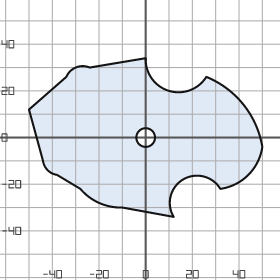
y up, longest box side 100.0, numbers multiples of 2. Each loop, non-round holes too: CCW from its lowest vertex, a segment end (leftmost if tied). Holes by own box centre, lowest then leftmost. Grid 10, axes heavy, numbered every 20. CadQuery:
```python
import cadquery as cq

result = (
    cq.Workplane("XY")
    .moveTo(12.0, -34.0)
    .threePointArc((16.0, -18.0), (32.0, -22.0))
    .threePointArc((44.0, -16.0), (50.0, -4.0))
    .threePointArc((42.0, 14.0), (26.0, 26.0))
    .threePointArc((10.0, 20.0), (0.0, 34.0))
    .lineTo(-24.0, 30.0)
    .threePointArc((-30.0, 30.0), (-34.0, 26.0))
    .lineTo(-50.0, 12.0)
    .lineTo(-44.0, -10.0)
    .threePointArc((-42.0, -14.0), (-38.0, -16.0))
    .lineTo(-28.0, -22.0)
    .threePointArc((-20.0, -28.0), (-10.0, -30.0))
    .close()
    .moveTo(0.0, 0.0)
    .circle(4.0)
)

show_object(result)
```